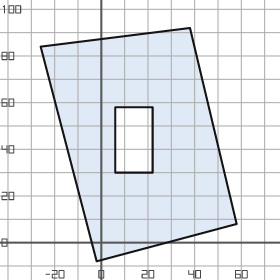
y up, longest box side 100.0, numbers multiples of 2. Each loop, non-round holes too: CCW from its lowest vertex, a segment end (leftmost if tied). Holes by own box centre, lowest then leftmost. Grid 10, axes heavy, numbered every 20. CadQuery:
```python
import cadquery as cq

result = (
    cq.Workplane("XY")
    .moveTo(-2.0, -8.0)
    .lineTo(58.0, 8.0)
    .lineTo(38.0, 92.0)
    .lineTo(-26.0, 84.0)
    .close()
    .moveTo(6.0, 30.0)
    .lineTo(22.0, 30.0)
    .lineTo(22.0, 58.0)
    .lineTo(6.0, 58.0)
    .close()
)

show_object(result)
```